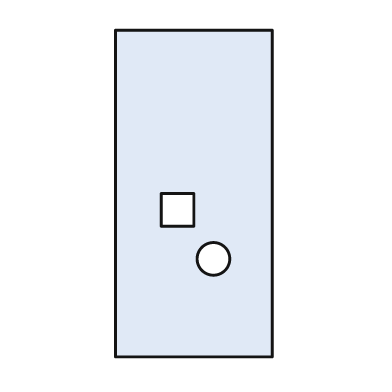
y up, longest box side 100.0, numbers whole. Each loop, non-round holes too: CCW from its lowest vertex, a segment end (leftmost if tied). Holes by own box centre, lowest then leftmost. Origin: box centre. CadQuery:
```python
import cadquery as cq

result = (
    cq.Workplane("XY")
    .moveTo(-24.0, -50.0)
    .lineTo(24.0, -50.0)
    .lineTo(24.0, 50.0)
    .lineTo(-24.0, 50.0)
    .close()
    .moveTo(6.0, -20.0)
    .circle(5.0)
    .moveTo(-10.0, -10.0)
    .lineTo(0.0, -10.0)
    .lineTo(0.0, 0.0)
    .lineTo(-10.0, 0.0)
    .close()
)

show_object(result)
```